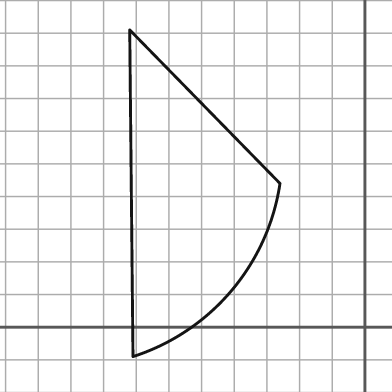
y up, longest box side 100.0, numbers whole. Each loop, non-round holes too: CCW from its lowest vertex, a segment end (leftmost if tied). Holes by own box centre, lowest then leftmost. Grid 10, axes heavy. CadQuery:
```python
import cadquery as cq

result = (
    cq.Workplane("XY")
    .moveTo(-71.0, -9.0)
    .threePointArc((-41.0, 11.0), (-26.0, 44.0))
    .lineTo(-72.0, 91.0)
    .close()
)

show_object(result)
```